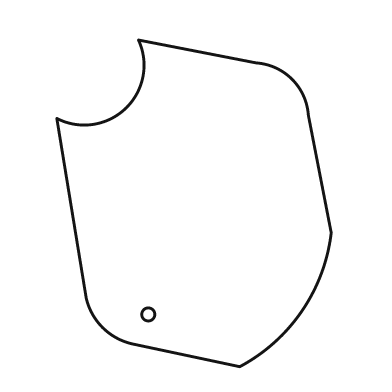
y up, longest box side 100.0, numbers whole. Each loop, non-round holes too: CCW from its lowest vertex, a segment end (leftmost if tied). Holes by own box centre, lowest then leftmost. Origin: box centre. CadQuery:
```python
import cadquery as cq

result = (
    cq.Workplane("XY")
    .moveTo(14.0, -50.0)
    .threePointArc((33.0, -33.0), (42.0, -9.0))
    .lineTo(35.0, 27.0)
    .threePointArc((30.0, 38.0), (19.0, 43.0))
    .lineTo(-17.0, 50.0)
    .threePointArc((-21.0, 29.0), (-42.0, 26.0))
    .lineTo(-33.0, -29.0)
    .threePointArc((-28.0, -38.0), (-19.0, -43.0))
    .close()
    .moveTo(-14.0, -34.0)
    .circle(2.0)
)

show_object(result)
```